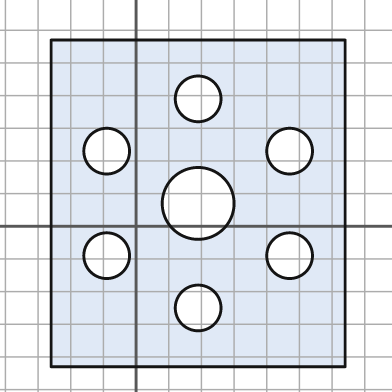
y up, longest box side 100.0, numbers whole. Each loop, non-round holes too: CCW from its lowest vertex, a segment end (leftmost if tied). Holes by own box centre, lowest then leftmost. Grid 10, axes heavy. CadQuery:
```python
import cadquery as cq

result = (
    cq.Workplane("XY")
    .moveTo(-26.0, -43.0)
    .lineTo(64.0, -43.0)
    .lineTo(64.0, 57.0)
    .lineTo(-26.0, 57.0)
    .close()
    .moveTo(19.0, -25.0)
    .circle(7.0)
    .moveTo(-9.0, -9.0)
    .circle(7.0)
    .moveTo(47.0, -9.0)
    .circle(7.0)
    .moveTo(19.0, 7.0)
    .circle(11.0)
    .moveTo(-9.0, 23.0)
    .circle(7.0)
    .moveTo(47.0, 23.0)
    .circle(7.0)
    .moveTo(19.0, 39.0)
    .circle(7.0)
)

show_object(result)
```